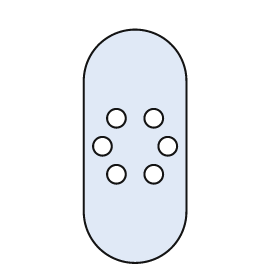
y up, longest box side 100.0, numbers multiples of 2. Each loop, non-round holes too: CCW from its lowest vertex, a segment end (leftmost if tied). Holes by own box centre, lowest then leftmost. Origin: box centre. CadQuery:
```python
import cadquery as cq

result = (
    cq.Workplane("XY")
    .moveTo(-22.0, -28.0)
    .threePointArc((0.0, -50.0), (22.0, -28.0))
    .lineTo(22.0, 28.0)
    .threePointArc((0.0, 50.0), (-22.0, 28.0))
    .close()
    .moveTo(-8.0, -12.0)
    .circle(4.0)
    .moveTo(8.0, -12.0)
    .circle(4.0)
    .moveTo(-14.0, 0.0)
    .circle(4.0)
    .moveTo(14.0, 0.0)
    .circle(4.0)
    .moveTo(-8.0, 12.0)
    .circle(4.0)
    .moveTo(8.0, 12.0)
    .circle(4.0)
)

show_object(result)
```